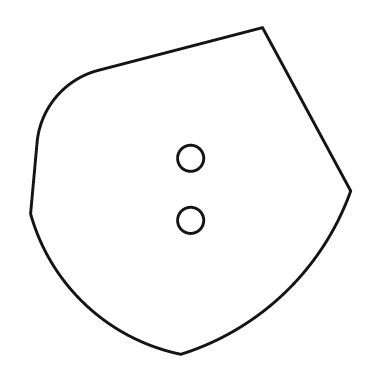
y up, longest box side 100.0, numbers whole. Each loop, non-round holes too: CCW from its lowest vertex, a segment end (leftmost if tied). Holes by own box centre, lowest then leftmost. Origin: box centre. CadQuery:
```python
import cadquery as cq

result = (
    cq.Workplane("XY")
    .moveTo(-3.0, -50.0)
    .threePointArc((29.0, -31.0), (49.0, 0.0))
    .lineTo(22.0, 50.0)
    .lineTo(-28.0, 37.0)
    .threePointArc((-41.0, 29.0), (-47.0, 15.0))
    .lineTo(-49.0, -7.0)
    .threePointArc((-32.0, -35.0), (-3.0, -50.0))
    .close()
    .moveTo(0.0, -9.0)
    .circle(4.0)
    .moveTo(0.0, 10.0)
    .circle(4.0)
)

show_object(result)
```